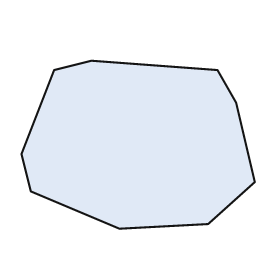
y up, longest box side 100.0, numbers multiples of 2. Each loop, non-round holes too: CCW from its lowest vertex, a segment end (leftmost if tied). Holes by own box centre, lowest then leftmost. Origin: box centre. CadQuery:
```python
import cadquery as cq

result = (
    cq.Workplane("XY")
    .moveTo(-8.0, -36.0)
    .lineTo(30.0, -34.0)
    .lineTo(50.0, -16.0)
    .lineTo(42.0, 18.0)
    .lineTo(34.0, 32.0)
    .lineTo(-20.0, 36.0)
    .lineTo(-36.0, 32.0)
    .lineTo(-50.0, -4.0)
    .lineTo(-46.0, -20.0)
    .close()
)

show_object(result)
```